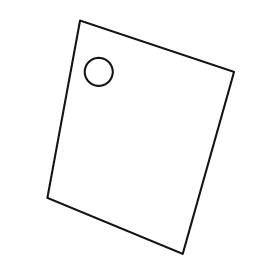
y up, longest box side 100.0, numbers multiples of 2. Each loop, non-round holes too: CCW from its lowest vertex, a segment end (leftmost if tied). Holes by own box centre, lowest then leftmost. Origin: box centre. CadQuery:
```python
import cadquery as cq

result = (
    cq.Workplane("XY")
    .moveTo(18.0, -50.0)
    .lineTo(40.0, 28.0)
    .lineTo(-26.0, 50.0)
    .lineTo(-40.0, -26.0)
    .close()
    .moveTo(-18.0, 28.0)
    .circle(6.0)
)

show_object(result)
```